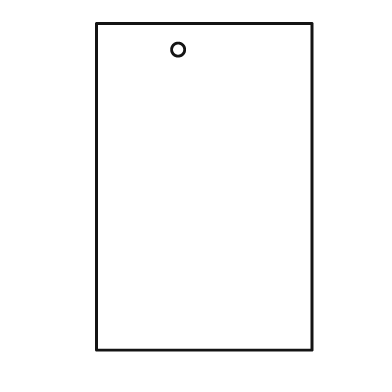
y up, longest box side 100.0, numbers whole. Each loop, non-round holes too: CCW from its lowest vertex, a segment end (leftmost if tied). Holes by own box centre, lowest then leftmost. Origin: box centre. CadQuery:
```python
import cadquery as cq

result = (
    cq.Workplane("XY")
    .moveTo(-33.0, -50.0)
    .lineTo(33.0, -50.0)
    .lineTo(33.0, 50.0)
    .lineTo(-33.0, 50.0)
    .close()
    .moveTo(-8.0, 42.0)
    .circle(2.0)
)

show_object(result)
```